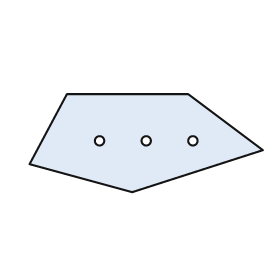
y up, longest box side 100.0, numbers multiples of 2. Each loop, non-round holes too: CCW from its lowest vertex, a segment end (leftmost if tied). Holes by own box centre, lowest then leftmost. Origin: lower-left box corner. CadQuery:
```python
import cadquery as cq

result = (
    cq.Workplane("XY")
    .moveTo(44.0, 0.0)
    .lineTo(100.0, 18.0)
    .lineTo(68.0, 42.0)
    .lineTo(16.0, 42.0)
    .lineTo(0.0, 12.0)
    .close()
    .moveTo(30.0, 22.0)
    .circle(2.0)
    .moveTo(50.0, 22.0)
    .circle(2.0)
    .moveTo(70.0, 22.0)
    .circle(2.0)
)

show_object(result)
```